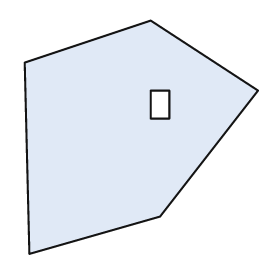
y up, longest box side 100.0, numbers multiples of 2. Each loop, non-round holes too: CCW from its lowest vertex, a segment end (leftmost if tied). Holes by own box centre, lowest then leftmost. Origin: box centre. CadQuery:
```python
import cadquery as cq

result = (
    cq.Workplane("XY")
    .moveTo(-48.0, -50.0)
    .lineTo(8.0, -34.0)
    .lineTo(50.0, 20.0)
    .lineTo(4.0, 50.0)
    .lineTo(-50.0, 32.0)
    .close()
    .moveTo(4.0, 8.0)
    .lineTo(12.0, 8.0)
    .lineTo(12.0, 20.0)
    .lineTo(4.0, 20.0)
    .close()
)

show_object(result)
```